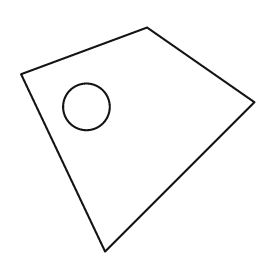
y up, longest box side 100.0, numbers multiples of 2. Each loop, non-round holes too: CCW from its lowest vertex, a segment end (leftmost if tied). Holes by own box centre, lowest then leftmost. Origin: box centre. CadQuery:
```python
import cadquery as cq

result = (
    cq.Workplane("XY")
    .moveTo(-14.0, -48.0)
    .lineTo(50.0, 16.0)
    .lineTo(4.0, 48.0)
    .lineTo(-50.0, 28.0)
    .close()
    .moveTo(-22.0, 14.0)
    .circle(10.0)
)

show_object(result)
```